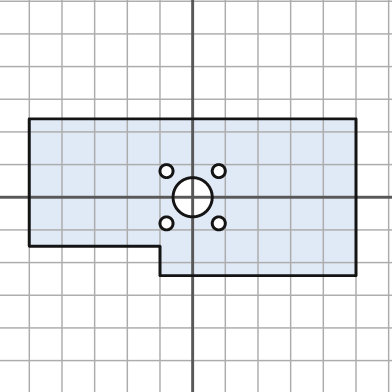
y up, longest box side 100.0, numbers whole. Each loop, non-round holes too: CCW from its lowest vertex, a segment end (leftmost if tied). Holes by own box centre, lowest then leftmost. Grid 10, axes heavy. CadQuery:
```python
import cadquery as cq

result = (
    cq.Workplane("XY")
    .moveTo(-10.0, -24.0)
    .lineTo(50.0, -24.0)
    .lineTo(50.0, 24.0)
    .lineTo(-50.0, 24.0)
    .lineTo(-50.0, -15.0)
    .lineTo(-10.0, -15.0)
    .close()
    .moveTo(-8.0, -8.0)
    .circle(2.0)
    .moveTo(8.0, -8.0)
    .circle(2.0)
    .moveTo(0.0, 0.0)
    .circle(6.0)
    .moveTo(-8.0, 8.0)
    .circle(2.0)
    .moveTo(8.0, 8.0)
    .circle(2.0)
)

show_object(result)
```